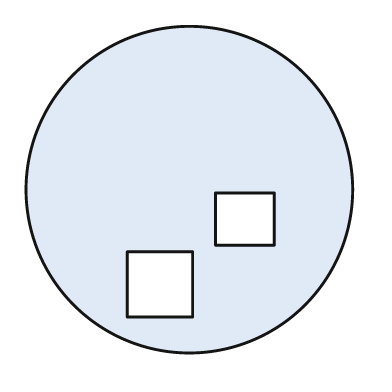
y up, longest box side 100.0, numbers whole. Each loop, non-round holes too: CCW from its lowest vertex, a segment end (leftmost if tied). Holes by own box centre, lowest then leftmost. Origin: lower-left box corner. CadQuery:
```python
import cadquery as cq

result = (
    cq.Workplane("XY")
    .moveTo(50.0, 50.0)
    .circle(50.0)
    .moveTo(31.0, 11.0)
    .lineTo(51.0, 11.0)
    .lineTo(51.0, 31.0)
    .lineTo(31.0, 31.0)
    .close()
    .moveTo(58.0, 33.0)
    .lineTo(76.0, 33.0)
    .lineTo(76.0, 49.0)
    .lineTo(58.0, 49.0)
    .close()
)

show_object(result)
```